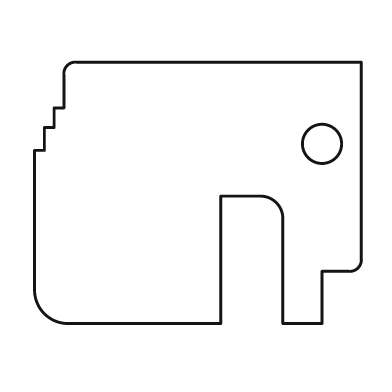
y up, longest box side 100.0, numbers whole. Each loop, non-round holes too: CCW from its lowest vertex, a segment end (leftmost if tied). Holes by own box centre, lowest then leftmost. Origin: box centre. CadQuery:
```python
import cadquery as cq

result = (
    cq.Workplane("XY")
    .moveTo(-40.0, -40.0)
    .lineTo(7.0, -40.0)
    .lineTo(7.0, -1.0)
    .lineTo(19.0, -1.0)
    .threePointArc((24.0, -3.0), (26.0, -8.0))
    .lineTo(26.0, -40.0)
    .lineTo(38.0, -40.0)
    .lineTo(38.0, -24.0)
    .lineTo(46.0, -24.0)
    .threePointArc((49.0, -23.0), (50.0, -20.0))
    .lineTo(50.0, 40.0)
    .lineTo(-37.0, 40.0)
    .threePointArc((-40.0, 39.0), (-41.0, 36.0))
    .lineTo(-41.0, 26.0)
    .lineTo(-44.0, 26.0)
    .lineTo(-44.0, 20.0)
    .lineTo(-47.0, 20.0)
    .lineTo(-47.0, 13.0)
    .lineTo(-50.0, 13.0)
    .lineTo(-50.0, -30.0)
    .threePointArc((-47.0, -37.0), (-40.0, -40.0))
    .close()
    .moveTo(38.0, 15.0)
    .circle(6.0)
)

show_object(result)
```